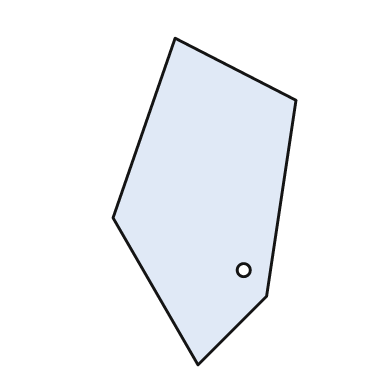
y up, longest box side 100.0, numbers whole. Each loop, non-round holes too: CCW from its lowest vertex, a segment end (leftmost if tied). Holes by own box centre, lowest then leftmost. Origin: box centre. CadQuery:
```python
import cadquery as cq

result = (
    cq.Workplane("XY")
    .moveTo(-2.0, -50.0)
    .lineTo(19.0, -29.0)
    .lineTo(28.0, 31.0)
    .lineTo(-9.0, 50.0)
    .lineTo(-28.0, -5.0)
    .close()
    .moveTo(12.0, -21.0)
    .circle(2.0)
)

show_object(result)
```